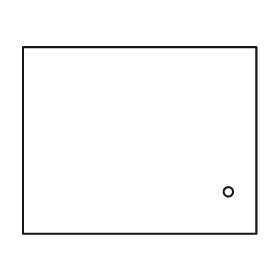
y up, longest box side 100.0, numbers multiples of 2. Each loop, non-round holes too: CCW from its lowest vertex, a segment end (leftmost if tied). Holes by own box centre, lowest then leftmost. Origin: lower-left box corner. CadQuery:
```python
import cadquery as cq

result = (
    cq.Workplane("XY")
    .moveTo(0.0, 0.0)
    .lineTo(100.0, 0.0)
    .lineTo(100.0, 80.0)
    .lineTo(0.0, 80.0)
    .close()
    .moveTo(88.0, 18.0)
    .circle(2.0)
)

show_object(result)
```